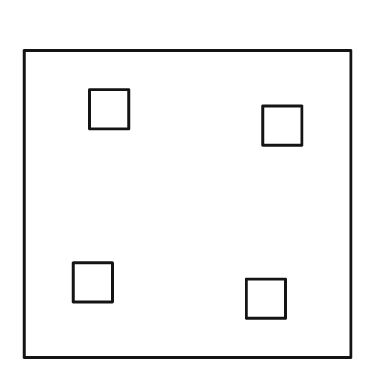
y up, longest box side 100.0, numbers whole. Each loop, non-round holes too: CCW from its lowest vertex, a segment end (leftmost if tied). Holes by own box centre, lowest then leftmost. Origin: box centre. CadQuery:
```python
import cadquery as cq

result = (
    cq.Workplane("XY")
    .moveTo(-50.0, -47.0)
    .lineTo(50.0, -47.0)
    .lineTo(50.0, 47.0)
    .lineTo(-50.0, 47.0)
    .close()
    .moveTo(18.0, -35.0)
    .lineTo(30.0, -35.0)
    .lineTo(30.0, -23.0)
    .lineTo(18.0, -23.0)
    .close()
    .moveTo(-35.0, -30.0)
    .lineTo(-23.0, -30.0)
    .lineTo(-23.0, -18.0)
    .lineTo(-35.0, -18.0)
    .close()
    .moveTo(23.0, 18.0)
    .lineTo(35.0, 18.0)
    .lineTo(35.0, 30.0)
    .lineTo(23.0, 30.0)
    .close()
    .moveTo(-30.0, 23.0)
    .lineTo(-18.0, 23.0)
    .lineTo(-18.0, 35.0)
    .lineTo(-30.0, 35.0)
    .close()
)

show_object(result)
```